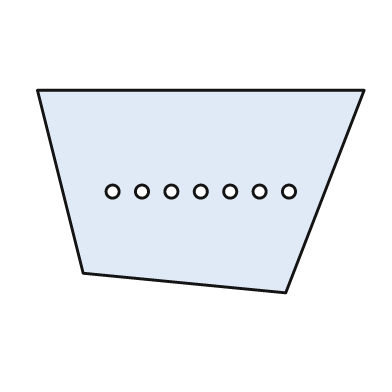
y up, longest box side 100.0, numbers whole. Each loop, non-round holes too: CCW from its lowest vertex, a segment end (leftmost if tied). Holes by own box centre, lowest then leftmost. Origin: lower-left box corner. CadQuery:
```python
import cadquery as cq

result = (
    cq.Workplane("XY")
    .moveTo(76.0, 0.0)
    .lineTo(100.0, 62.0)
    .lineTo(0.0, 62.0)
    .lineTo(14.0, 6.0)
    .close()
    .moveTo(23.0, 31.0)
    .circle(2.0)
    .moveTo(32.0, 31.0)
    .circle(2.0)
    .moveTo(41.0, 31.0)
    .circle(2.0)
    .moveTo(50.0, 31.0)
    .circle(2.0)
    .moveTo(59.0, 31.0)
    .circle(2.0)
    .moveTo(68.0, 31.0)
    .circle(2.0)
    .moveTo(77.0, 31.0)
    .circle(2.0)
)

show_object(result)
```